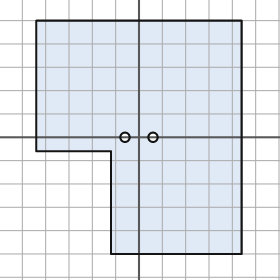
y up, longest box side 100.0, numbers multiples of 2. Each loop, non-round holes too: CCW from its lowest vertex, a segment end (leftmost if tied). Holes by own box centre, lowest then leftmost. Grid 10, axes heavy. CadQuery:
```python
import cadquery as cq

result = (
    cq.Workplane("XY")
    .moveTo(-12.0, -50.0)
    .lineTo(44.0, -50.0)
    .lineTo(44.0, 50.0)
    .lineTo(-44.0, 50.0)
    .lineTo(-44.0, -6.0)
    .lineTo(-12.0, -6.0)
    .close()
    .moveTo(-6.0, 0.0)
    .circle(2.0)
    .moveTo(6.0, 0.0)
    .circle(2.0)
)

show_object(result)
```